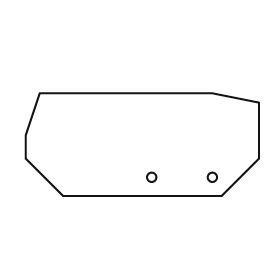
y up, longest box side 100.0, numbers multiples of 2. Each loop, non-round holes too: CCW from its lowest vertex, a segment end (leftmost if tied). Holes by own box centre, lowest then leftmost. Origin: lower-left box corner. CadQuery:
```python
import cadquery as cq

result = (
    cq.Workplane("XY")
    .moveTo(16.0, 0.0)
    .lineTo(84.0, 0.0)
    .lineTo(100.0, 16.0)
    .lineTo(100.0, 40.0)
    .lineTo(80.0, 44.0)
    .lineTo(6.0, 44.0)
    .lineTo(0.0, 26.0)
    .lineTo(0.0, 16.0)
    .close()
    .moveTo(54.0, 8.0)
    .circle(2.0)
    .moveTo(80.0, 8.0)
    .circle(2.0)
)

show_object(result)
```